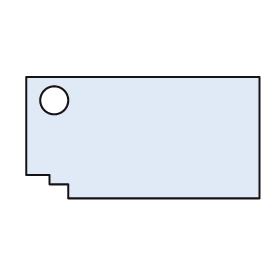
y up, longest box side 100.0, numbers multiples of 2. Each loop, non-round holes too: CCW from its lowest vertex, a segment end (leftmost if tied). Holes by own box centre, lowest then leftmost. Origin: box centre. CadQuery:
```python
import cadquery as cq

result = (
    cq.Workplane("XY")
    .moveTo(-32.0, -26.0)
    .lineTo(50.0, -26.0)
    .lineTo(50.0, 26.0)
    .lineTo(-50.0, 26.0)
    .lineTo(-50.0, -16.0)
    .lineTo(-40.0, -16.0)
    .lineTo(-40.0, -20.0)
    .lineTo(-32.0, -20.0)
    .close()
    .moveTo(-38.0, 16.0)
    .circle(6.0)
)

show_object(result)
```